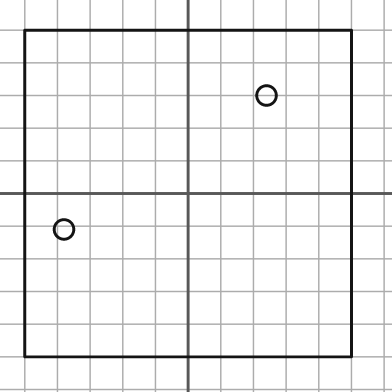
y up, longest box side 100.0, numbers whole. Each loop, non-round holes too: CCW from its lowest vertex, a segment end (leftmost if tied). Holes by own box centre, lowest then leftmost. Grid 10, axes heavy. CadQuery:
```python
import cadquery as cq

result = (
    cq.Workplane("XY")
    .moveTo(-50.0, -50.0)
    .lineTo(50.0, -50.0)
    .lineTo(50.0, 50.0)
    .lineTo(-50.0, 50.0)
    .close()
    .moveTo(-38.0, -11.0)
    .circle(3.0)
    .moveTo(24.0, 30.0)
    .circle(3.0)
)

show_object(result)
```